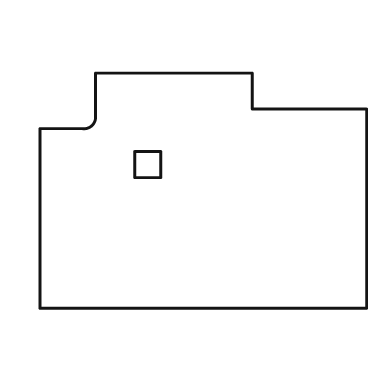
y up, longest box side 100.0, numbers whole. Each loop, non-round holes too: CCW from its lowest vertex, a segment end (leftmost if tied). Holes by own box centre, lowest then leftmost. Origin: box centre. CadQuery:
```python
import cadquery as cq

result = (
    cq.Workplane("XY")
    .moveTo(-50.0, -36.0)
    .lineTo(50.0, -36.0)
    .lineTo(50.0, 25.0)
    .lineTo(15.0, 25.0)
    .lineTo(15.0, 36.0)
    .lineTo(-33.0, 36.0)
    .lineTo(-33.0, 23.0)
    .threePointArc((-34.0, 20.0), (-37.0, 19.0))
    .lineTo(-50.0, 19.0)
    .close()
    .moveTo(-21.0, 4.0)
    .lineTo(-13.0, 4.0)
    .lineTo(-13.0, 12.0)
    .lineTo(-21.0, 12.0)
    .close()
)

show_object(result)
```